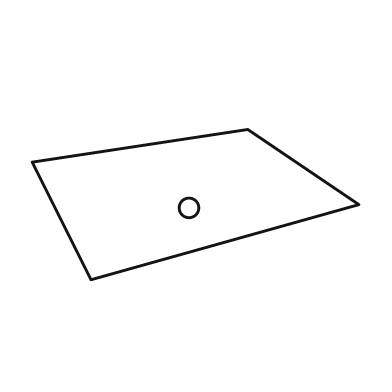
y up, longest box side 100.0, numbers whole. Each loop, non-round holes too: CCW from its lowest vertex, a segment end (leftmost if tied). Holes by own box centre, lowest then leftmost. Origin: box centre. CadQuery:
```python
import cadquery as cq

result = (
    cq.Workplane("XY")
    .moveTo(-32.0, -23.0)
    .lineTo(50.0, 0.0)
    .lineTo(16.0, 23.0)
    .lineTo(-50.0, 13.0)
    .close()
    .moveTo(-2.0, -1.0)
    .circle(3.0)
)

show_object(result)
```